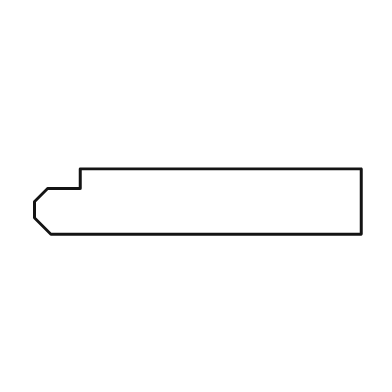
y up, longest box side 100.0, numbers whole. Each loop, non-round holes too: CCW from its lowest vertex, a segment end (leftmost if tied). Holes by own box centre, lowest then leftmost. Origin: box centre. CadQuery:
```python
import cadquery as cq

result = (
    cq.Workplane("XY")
    .moveTo(-45.0, -10.0)
    .lineTo(50.0, -10.0)
    .lineTo(50.0, 10.0)
    .lineTo(-36.0, 10.0)
    .lineTo(-36.0, 4.0)
    .lineTo(-46.0, 4.0)
    .lineTo(-50.0, 0.0)
    .lineTo(-50.0, -5.0)
    .close()
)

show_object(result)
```